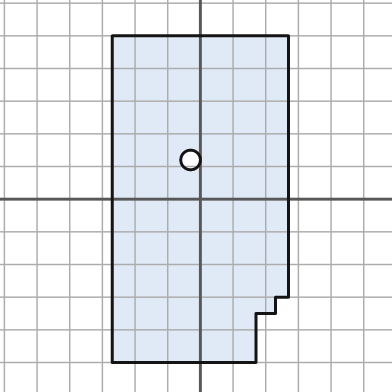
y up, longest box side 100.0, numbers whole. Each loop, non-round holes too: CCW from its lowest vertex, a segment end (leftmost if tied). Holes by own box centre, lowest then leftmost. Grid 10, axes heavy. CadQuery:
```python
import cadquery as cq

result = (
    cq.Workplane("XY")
    .moveTo(-27.0, -50.0)
    .lineTo(17.0, -50.0)
    .lineTo(17.0, -35.0)
    .lineTo(23.0, -35.0)
    .lineTo(23.0, -30.0)
    .lineTo(27.0, -30.0)
    .lineTo(27.0, 50.0)
    .lineTo(-27.0, 50.0)
    .close()
    .moveTo(-3.0, 12.0)
    .circle(3.0)
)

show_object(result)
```